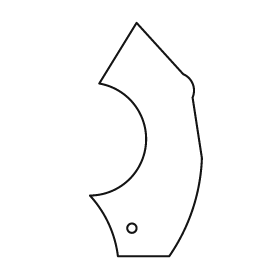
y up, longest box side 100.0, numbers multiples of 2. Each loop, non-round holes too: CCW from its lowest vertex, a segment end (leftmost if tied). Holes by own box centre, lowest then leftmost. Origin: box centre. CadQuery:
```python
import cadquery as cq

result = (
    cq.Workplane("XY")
    .moveTo(-12.0, -50.0)
    .lineTo(10.0, -50.0)
    .threePointArc((20.0, -30.0), (24.0, -8.0))
    .lineTo(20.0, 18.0)
    .threePointArc((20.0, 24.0), (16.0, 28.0))
    .lineTo(-4.0, 50.0)
    .lineTo(-20.0, 24.0)
    .threePointArc((0.0, -2.0), (-24.0, -24.0))
    .threePointArc((-16.0, -36.0), (-12.0, -50.0))
    .close()
    .moveTo(-6.0, -38.0)
    .circle(2.0)
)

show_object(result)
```